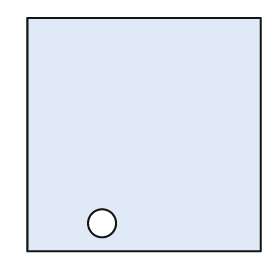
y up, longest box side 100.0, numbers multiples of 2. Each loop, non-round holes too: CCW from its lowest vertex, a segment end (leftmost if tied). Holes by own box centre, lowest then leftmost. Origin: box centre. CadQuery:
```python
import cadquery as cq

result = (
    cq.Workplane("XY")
    .moveTo(-50.0, -50.0)
    .lineTo(50.0, -50.0)
    .lineTo(50.0, 50.0)
    .lineTo(-50.0, 50.0)
    .close()
    .moveTo(-18.0, -38.0)
    .circle(6.0)
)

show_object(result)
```